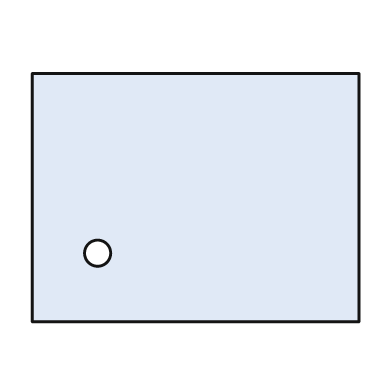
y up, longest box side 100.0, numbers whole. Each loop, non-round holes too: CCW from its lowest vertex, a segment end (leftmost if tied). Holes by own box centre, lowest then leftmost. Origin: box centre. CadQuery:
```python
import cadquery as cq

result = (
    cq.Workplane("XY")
    .moveTo(-50.0, -38.0)
    .lineTo(50.0, -38.0)
    .lineTo(50.0, 38.0)
    .lineTo(-50.0, 38.0)
    .close()
    .moveTo(-30.0, -17.0)
    .circle(4.0)
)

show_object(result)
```